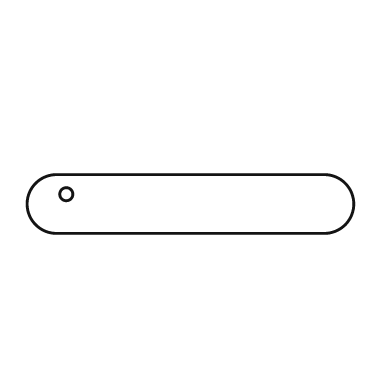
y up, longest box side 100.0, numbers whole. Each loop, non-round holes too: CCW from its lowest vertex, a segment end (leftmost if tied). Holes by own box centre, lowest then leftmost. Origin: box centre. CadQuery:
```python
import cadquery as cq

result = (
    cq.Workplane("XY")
    .moveTo(-41.0, -9.0)
    .lineTo(41.0, -9.0)
    .threePointArc((50.0, 0.0), (41.0, 9.0))
    .lineTo(-41.0, 9.0)
    .threePointArc((-50.0, 0.0), (-41.0, -9.0))
    .close()
    .moveTo(-38.0, 3.0)
    .circle(2.0)
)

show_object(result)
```